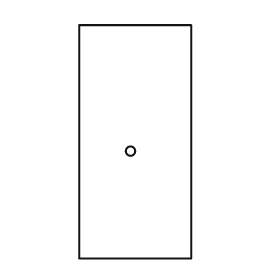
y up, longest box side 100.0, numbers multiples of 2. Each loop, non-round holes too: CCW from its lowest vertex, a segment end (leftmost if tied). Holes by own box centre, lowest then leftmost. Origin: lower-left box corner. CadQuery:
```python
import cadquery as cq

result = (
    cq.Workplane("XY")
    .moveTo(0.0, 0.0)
    .lineTo(48.0, 0.0)
    .lineTo(48.0, 100.0)
    .lineTo(0.0, 100.0)
    .close()
    .moveTo(22.0, 46.0)
    .circle(2.0)
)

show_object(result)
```